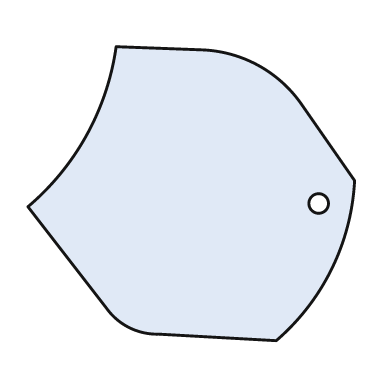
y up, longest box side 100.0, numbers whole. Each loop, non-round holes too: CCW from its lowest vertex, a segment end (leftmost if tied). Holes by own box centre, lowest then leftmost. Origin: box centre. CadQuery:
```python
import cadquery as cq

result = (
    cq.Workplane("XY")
    .moveTo(26.0, -45.0)
    .threePointArc((43.0, -23.0), (50.0, 4.0))
    .lineTo(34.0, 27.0)
    .threePointArc((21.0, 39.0), (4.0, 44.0))
    .lineTo(-23.0, 45.0)
    .threePointArc((-32.0, 18.0), (-50.0, -4.0))
    .lineTo(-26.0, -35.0)
    .threePointArc((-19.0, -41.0), (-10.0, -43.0))
    .close()
    .moveTo(39.0, -3.0)
    .circle(3.0)
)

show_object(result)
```